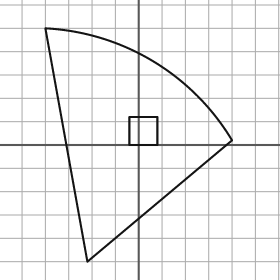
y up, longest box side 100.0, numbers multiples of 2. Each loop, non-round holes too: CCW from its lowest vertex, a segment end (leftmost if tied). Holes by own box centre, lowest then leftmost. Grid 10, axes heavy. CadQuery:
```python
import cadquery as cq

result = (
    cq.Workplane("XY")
    .moveTo(-22.0, -50.0)
    .lineTo(40.0, 2.0)
    .threePointArc((6.0, 36.0), (-40.0, 50.0))
    .close()
    .moveTo(-4.0, 0.0)
    .lineTo(8.0, 0.0)
    .lineTo(8.0, 12.0)
    .lineTo(-4.0, 12.0)
    .close()
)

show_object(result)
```